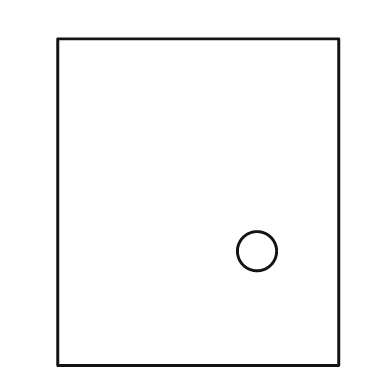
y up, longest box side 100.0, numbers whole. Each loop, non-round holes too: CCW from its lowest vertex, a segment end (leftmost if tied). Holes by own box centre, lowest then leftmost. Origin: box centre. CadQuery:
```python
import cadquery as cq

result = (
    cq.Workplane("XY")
    .moveTo(-43.0, -50.0)
    .lineTo(43.0, -50.0)
    .lineTo(43.0, 50.0)
    .lineTo(-43.0, 50.0)
    .close()
    .moveTo(18.0, -15.0)
    .circle(6.0)
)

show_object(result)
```